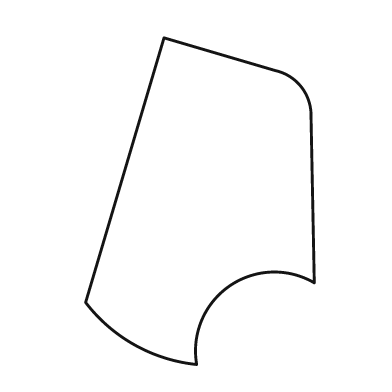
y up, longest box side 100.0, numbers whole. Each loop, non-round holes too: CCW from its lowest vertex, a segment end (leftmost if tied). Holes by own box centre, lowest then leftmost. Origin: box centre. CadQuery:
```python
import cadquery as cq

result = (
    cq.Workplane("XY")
    .moveTo(-1.0, -50.0)
    .threePointArc((9.0, -26.0), (35.0, -25.0))
    .lineTo(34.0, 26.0)
    .threePointArc((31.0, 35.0), (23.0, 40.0))
    .lineTo(-11.0, 50.0)
    .lineTo(-35.0, -31.0)
    .threePointArc((-20.0, -44.0), (-1.0, -50.0))
    .close()
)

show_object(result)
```